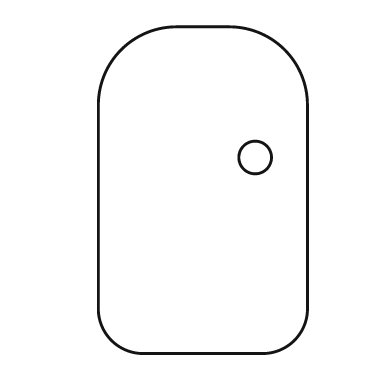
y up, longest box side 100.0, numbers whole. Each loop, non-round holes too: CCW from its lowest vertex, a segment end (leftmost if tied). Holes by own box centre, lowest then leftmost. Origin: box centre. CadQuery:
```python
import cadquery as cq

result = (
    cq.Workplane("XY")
    .moveTo(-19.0, -50.0)
    .lineTo(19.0, -50.0)
    .threePointArc((28.0, -46.0), (32.0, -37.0))
    .lineTo(32.0, 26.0)
    .threePointArc((25.0, 43.0), (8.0, 50.0))
    .lineTo(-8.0, 50.0)
    .threePointArc((-25.0, 43.0), (-32.0, 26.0))
    .lineTo(-32.0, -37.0)
    .threePointArc((-28.0, -46.0), (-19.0, -50.0))
    .close()
    .moveTo(16.0, 10.0)
    .circle(5.0)
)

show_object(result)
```